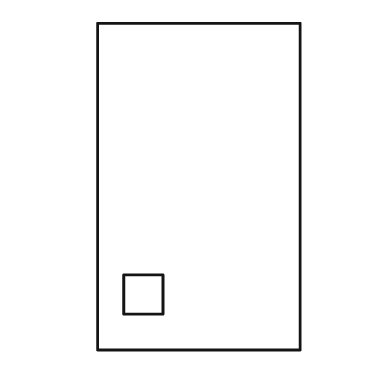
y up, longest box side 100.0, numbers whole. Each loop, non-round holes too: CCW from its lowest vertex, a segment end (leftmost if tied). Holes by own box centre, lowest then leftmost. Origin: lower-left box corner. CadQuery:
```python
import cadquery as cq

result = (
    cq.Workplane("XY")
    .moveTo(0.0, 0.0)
    .lineTo(62.0, 0.0)
    .lineTo(62.0, 100.0)
    .lineTo(0.0, 100.0)
    .close()
    .moveTo(8.0, 11.0)
    .lineTo(20.0, 11.0)
    .lineTo(20.0, 23.0)
    .lineTo(8.0, 23.0)
    .close()
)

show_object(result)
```